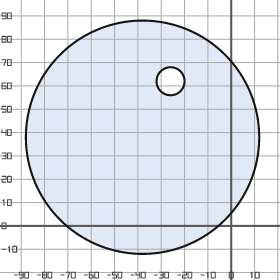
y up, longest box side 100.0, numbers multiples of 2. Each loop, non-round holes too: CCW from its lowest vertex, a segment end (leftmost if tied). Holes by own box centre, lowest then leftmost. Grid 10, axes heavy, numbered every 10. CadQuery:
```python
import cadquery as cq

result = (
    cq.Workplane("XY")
    .moveTo(-38.0, 38.0)
    .circle(50.0)
    .moveTo(-26.0, 62.0)
    .circle(6.0)
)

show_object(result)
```